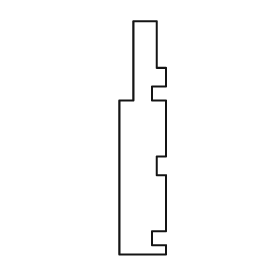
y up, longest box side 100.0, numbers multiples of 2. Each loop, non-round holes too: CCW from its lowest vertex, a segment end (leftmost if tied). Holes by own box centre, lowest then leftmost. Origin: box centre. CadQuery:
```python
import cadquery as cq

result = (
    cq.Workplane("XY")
    .moveTo(-10.0, -50.0)
    .lineTo(10.0, -50.0)
    .lineTo(10.0, -46.0)
    .lineTo(4.0, -46.0)
    .lineTo(4.0, -40.0)
    .lineTo(10.0, -40.0)
    .lineTo(10.0, -16.0)
    .lineTo(6.0, -16.0)
    .lineTo(6.0, -8.0)
    .lineTo(10.0, -8.0)
    .lineTo(10.0, 16.0)
    .lineTo(4.0, 16.0)
    .lineTo(4.0, 22.0)
    .lineTo(10.0, 22.0)
    .lineTo(10.0, 30.0)
    .lineTo(6.0, 30.0)
    .lineTo(6.0, 50.0)
    .lineTo(-4.0, 50.0)
    .lineTo(-4.0, 16.0)
    .lineTo(-10.0, 16.0)
    .close()
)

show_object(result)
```